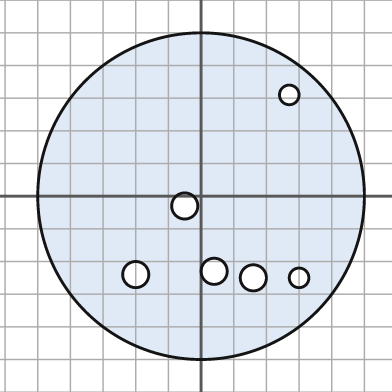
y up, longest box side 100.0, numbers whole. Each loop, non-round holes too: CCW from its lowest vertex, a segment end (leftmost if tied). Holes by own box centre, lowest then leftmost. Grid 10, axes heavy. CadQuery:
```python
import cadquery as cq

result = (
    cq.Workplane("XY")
    .moveTo(0.0, 0.0)
    .circle(50.0)
    .moveTo(16.0, -25.0)
    .circle(4.0)
    .moveTo(30.0, -25.0)
    .circle(3.0)
    .moveTo(-20.0, -24.0)
    .circle(4.0)
    .moveTo(4.0, -23.0)
    .circle(4.0)
    .moveTo(-5.0, -3.0)
    .circle(4.0)
    .moveTo(27.0, 31.0)
    .circle(3.0)
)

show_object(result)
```